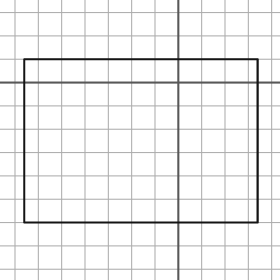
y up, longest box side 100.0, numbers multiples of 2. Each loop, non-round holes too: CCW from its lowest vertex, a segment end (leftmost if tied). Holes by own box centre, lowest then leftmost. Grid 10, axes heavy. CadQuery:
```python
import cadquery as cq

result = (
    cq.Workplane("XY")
    .moveTo(-66.0, -60.0)
    .lineTo(34.0, -60.0)
    .lineTo(34.0, 10.0)
    .lineTo(-66.0, 10.0)
    .close()
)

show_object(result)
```